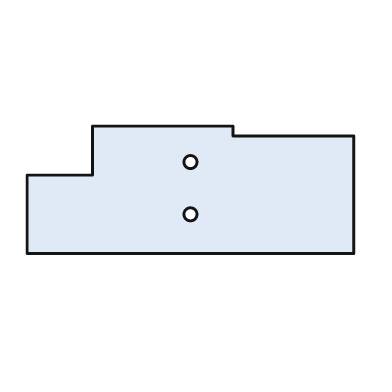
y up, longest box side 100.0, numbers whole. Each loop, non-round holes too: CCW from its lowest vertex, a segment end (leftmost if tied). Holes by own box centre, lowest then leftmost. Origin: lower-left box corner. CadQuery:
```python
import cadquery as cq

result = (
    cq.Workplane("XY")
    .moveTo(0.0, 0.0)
    .lineTo(100.0, 0.0)
    .lineTo(100.0, 36.0)
    .lineTo(63.0, 36.0)
    .lineTo(63.0, 39.0)
    .lineTo(20.0, 39.0)
    .lineTo(20.0, 24.0)
    .lineTo(0.0, 24.0)
    .close()
    .moveTo(50.0, 12.0)
    .circle(2.0)
    .moveTo(50.0, 28.0)
    .circle(2.0)
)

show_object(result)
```